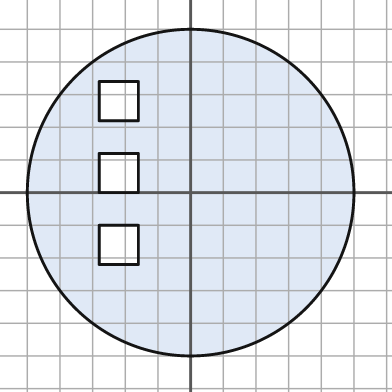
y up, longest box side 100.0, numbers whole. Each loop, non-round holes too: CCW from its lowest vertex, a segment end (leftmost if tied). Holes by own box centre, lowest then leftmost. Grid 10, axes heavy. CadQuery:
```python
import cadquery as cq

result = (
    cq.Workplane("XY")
    .moveTo(0.0, 0.0)
    .circle(50.0)
    .moveTo(-28.0, -22.0)
    .lineTo(-16.0, -22.0)
    .lineTo(-16.0, -10.0)
    .lineTo(-28.0, -10.0)
    .close()
    .moveTo(-28.0, 0.0)
    .lineTo(-16.0, 0.0)
    .lineTo(-16.0, 12.0)
    .lineTo(-28.0, 12.0)
    .close()
    .moveTo(-28.0, 22.0)
    .lineTo(-16.0, 22.0)
    .lineTo(-16.0, 34.0)
    .lineTo(-28.0, 34.0)
    .close()
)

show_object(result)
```